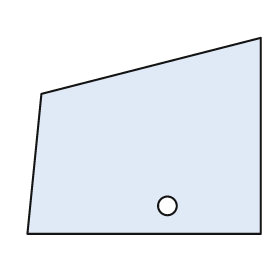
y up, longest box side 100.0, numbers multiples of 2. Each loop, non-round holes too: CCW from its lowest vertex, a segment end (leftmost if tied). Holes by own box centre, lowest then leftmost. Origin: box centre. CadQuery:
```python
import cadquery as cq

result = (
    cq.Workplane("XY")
    .moveTo(-50.0, -42.0)
    .lineTo(50.0, -42.0)
    .lineTo(50.0, 42.0)
    .lineTo(-44.0, 18.0)
    .close()
    .moveTo(10.0, -30.0)
    .circle(4.0)
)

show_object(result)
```